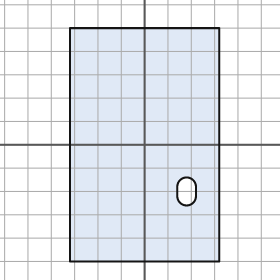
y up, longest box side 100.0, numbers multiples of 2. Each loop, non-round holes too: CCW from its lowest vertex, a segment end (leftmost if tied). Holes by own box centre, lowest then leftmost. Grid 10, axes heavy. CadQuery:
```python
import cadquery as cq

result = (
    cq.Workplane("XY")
    .moveTo(-32.0, -50.0)
    .lineTo(32.0, -50.0)
    .lineTo(32.0, 50.0)
    .lineTo(-32.0, 50.0)
    .close()
    .moveTo(14.0, -22.0)
    .threePointArc((18.0, -26.0), (22.0, -22.0))
    .lineTo(22.0, -18.0)
    .threePointArc((18.0, -14.0), (14.0, -18.0))
    .close()
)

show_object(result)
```